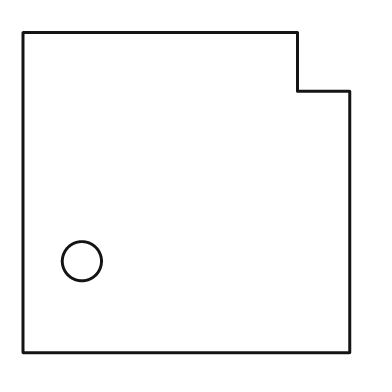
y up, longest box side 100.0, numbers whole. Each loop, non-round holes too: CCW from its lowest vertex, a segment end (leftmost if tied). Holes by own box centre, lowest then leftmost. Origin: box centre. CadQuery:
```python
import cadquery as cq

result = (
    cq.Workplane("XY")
    .moveTo(-50.0, -49.0)
    .lineTo(50.0, -49.0)
    .lineTo(50.0, 31.0)
    .lineTo(34.0, 31.0)
    .lineTo(34.0, 49.0)
    .lineTo(-50.0, 49.0)
    .close()
    .moveTo(-32.0, -21.0)
    .circle(6.0)
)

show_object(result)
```